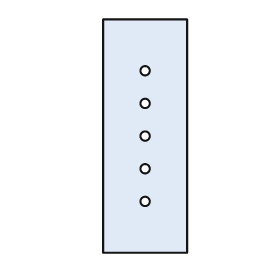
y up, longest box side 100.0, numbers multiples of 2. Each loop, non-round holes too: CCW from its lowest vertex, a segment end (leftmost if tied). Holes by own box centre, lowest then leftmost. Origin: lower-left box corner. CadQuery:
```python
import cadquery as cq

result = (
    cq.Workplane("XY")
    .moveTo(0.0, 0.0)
    .lineTo(36.0, 0.0)
    .lineTo(36.0, 100.0)
    .lineTo(0.0, 100.0)
    .close()
    .moveTo(18.0, 22.0)
    .circle(2.0)
    .moveTo(18.0, 36.0)
    .circle(2.0)
    .moveTo(18.0, 50.0)
    .circle(2.0)
    .moveTo(18.0, 64.0)
    .circle(2.0)
    .moveTo(18.0, 78.0)
    .circle(2.0)
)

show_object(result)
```